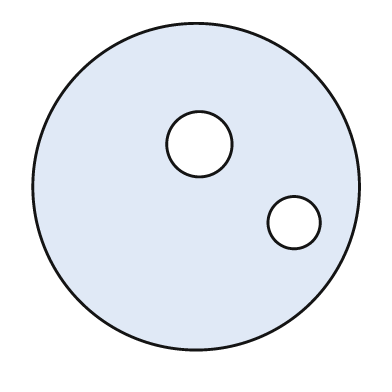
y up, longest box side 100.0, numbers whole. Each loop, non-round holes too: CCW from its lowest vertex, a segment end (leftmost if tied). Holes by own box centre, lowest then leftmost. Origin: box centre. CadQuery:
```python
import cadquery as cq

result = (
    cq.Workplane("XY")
    .moveTo(0.0, 0.0)
    .circle(50.0)
    .moveTo(30.0, -11.0)
    .circle(8.0)
    .moveTo(1.0, 13.0)
    .circle(10.0)
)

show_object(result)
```